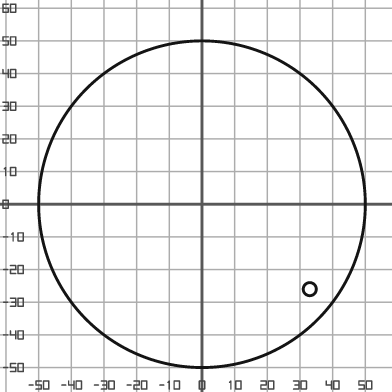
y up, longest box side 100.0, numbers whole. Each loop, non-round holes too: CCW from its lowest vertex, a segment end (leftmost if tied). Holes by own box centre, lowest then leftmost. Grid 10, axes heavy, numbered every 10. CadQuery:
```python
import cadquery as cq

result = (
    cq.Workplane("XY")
    .moveTo(0.0, 0.0)
    .circle(50.0)
    .moveTo(33.0, -26.0)
    .circle(2.0)
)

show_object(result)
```